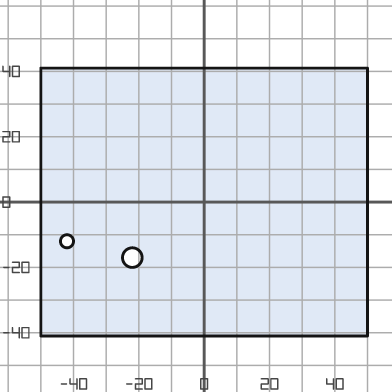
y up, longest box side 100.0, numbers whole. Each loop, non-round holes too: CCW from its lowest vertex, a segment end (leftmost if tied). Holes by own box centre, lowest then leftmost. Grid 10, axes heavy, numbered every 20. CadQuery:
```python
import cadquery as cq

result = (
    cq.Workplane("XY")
    .moveTo(-50.0, -41.0)
    .lineTo(50.0, -41.0)
    .lineTo(50.0, 41.0)
    .lineTo(-50.0, 41.0)
    .close()
    .moveTo(-22.0, -17.0)
    .circle(3.0)
    .moveTo(-42.0, -12.0)
    .circle(2.0)
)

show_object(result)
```